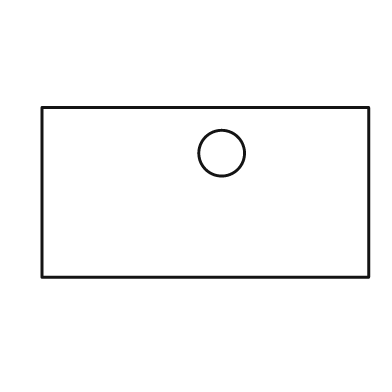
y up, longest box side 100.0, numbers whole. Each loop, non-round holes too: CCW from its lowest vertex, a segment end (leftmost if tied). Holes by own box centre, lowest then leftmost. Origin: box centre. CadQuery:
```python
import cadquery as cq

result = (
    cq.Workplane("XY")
    .moveTo(-50.0, -26.0)
    .lineTo(50.0, -26.0)
    .lineTo(50.0, 26.0)
    .lineTo(-50.0, 26.0)
    .close()
    .moveTo(5.0, 12.0)
    .circle(7.0)
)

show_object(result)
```